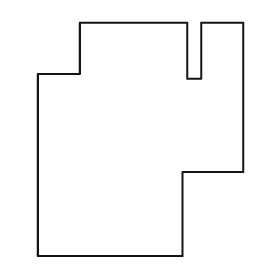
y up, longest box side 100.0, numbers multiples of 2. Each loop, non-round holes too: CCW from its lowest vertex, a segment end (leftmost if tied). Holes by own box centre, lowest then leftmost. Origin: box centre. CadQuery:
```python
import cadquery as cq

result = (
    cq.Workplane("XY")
    .moveTo(-44.0, -50.0)
    .lineTo(18.0, -50.0)
    .lineTo(18.0, -14.0)
    .lineTo(44.0, -14.0)
    .lineTo(44.0, 50.0)
    .lineTo(26.0, 50.0)
    .lineTo(26.0, 26.0)
    .lineTo(20.0, 26.0)
    .lineTo(20.0, 50.0)
    .lineTo(-26.0, 50.0)
    .lineTo(-26.0, 28.0)
    .lineTo(-44.0, 28.0)
    .close()
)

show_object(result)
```